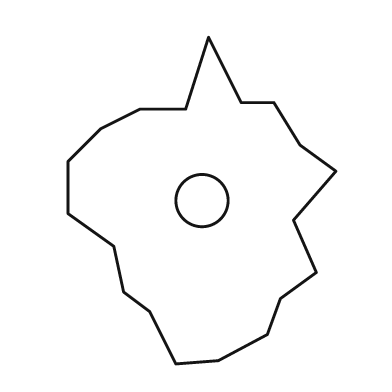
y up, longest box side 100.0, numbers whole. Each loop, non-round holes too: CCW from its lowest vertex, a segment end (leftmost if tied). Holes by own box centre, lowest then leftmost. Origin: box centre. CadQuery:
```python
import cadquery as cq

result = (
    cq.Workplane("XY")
    .moveTo(-8.0, -50.0)
    .lineTo(5.0, -49.0)
    .lineTo(20.0, -41.0)
    .lineTo(24.0, -30.0)
    .lineTo(35.0, -22.0)
    .lineTo(28.0, -6.0)
    .lineTo(41.0, 9.0)
    .lineTo(30.0, 17.0)
    .lineTo(22.0, 30.0)
    .lineTo(12.0, 30.0)
    .lineTo(2.0, 50.0)
    .lineTo(-5.0, 28.0)
    .lineTo(-19.0, 28.0)
    .lineTo(-31.0, 22.0)
    .lineTo(-41.0, 12.0)
    .lineTo(-41.0, -4.0)
    .lineTo(-27.0, -14.0)
    .lineTo(-24.0, -28.0)
    .lineTo(-16.0, -34.0)
    .close()
    .moveTo(0.0, 0.0)
    .circle(8.0)
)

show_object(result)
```